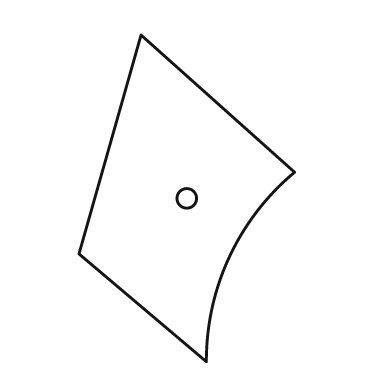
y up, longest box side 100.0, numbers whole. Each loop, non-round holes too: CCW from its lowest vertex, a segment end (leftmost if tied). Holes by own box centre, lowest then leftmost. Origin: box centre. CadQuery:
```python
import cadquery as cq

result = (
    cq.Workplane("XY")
    .moveTo(6.0, -50.0)
    .threePointArc((13.0, -18.0), (33.0, 8.0))
    .lineTo(-14.0, 50.0)
    .lineTo(-33.0, -17.0)
    .close()
    .moveTo(0.0, 0.0)
    .circle(3.0)
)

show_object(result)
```